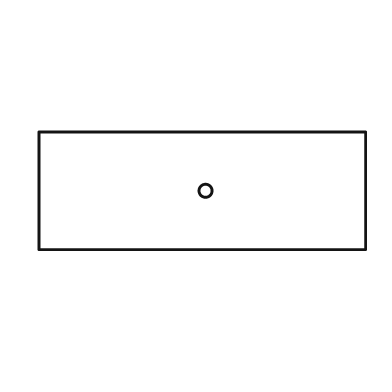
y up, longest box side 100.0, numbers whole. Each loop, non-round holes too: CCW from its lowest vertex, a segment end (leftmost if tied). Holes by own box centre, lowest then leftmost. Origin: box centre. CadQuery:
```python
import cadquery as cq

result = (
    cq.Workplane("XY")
    .moveTo(-50.0, -18.0)
    .lineTo(50.0, -18.0)
    .lineTo(50.0, 18.0)
    .lineTo(-50.0, 18.0)
    .close()
    .moveTo(1.0, 0.0)
    .circle(2.0)
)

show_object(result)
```